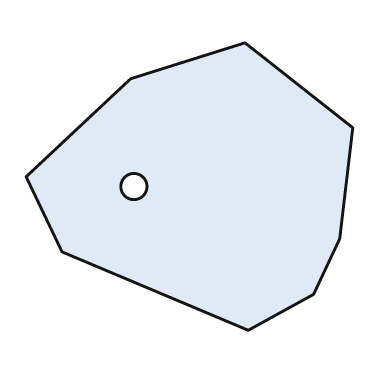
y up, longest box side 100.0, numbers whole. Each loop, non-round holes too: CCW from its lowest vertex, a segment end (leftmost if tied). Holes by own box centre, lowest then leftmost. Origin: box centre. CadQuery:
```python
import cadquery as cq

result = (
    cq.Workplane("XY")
    .moveTo(18.0, -44.0)
    .lineTo(38.0, -33.0)
    .lineTo(46.0, -16.0)
    .lineTo(50.0, 18.0)
    .lineTo(17.0, 44.0)
    .lineTo(-18.0, 33.0)
    .lineTo(-50.0, 3.0)
    .lineTo(-39.0, -20.0)
    .close()
    .moveTo(-17.0, 0.0)
    .circle(4.0)
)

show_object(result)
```